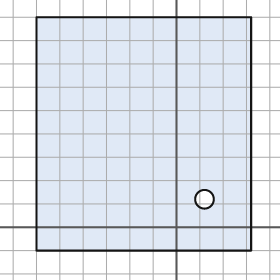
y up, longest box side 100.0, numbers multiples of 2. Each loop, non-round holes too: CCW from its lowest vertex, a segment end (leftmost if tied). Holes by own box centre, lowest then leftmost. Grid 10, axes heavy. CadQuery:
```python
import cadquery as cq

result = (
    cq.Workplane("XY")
    .moveTo(-60.0, -10.0)
    .lineTo(32.0, -10.0)
    .lineTo(32.0, 90.0)
    .lineTo(-60.0, 90.0)
    .close()
    .moveTo(12.0, 12.0)
    .circle(4.0)
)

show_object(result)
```